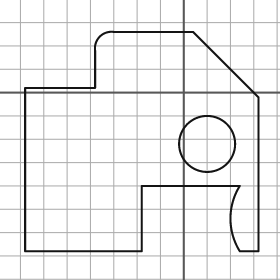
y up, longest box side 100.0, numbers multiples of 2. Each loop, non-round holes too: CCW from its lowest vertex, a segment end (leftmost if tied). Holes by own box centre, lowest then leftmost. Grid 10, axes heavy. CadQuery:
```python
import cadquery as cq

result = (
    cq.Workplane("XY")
    .moveTo(-68.0, -68.0)
    .lineTo(-18.0, -68.0)
    .lineTo(-18.0, -40.0)
    .lineTo(24.0, -40.0)
    .threePointArc((20.0, -54.0), (24.0, -68.0))
    .lineTo(32.0, -68.0)
    .lineTo(32.0, -2.0)
    .lineTo(4.0, 26.0)
    .lineTo(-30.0, 26.0)
    .threePointArc((-36.0, 24.0), (-38.0, 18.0))
    .lineTo(-38.0, 2.0)
    .lineTo(-68.0, 2.0)
    .close()
    .moveTo(10.0, -22.0)
    .circle(12.0)
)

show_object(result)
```